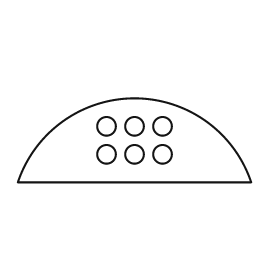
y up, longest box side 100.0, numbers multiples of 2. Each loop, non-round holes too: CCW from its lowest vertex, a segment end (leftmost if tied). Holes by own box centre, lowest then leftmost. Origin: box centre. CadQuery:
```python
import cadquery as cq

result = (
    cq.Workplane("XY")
    .moveTo(-50.0, -18.0)
    .lineTo(50.0, -18.0)
    .threePointArc((0.0, 18.0), (-50.0, -18.0))
    .close()
    .moveTo(-12.0, -6.0)
    .circle(4.0)
    .moveTo(0.0, -6.0)
    .circle(4.0)
    .moveTo(12.0, -6.0)
    .circle(4.0)
    .moveTo(-12.0, 6.0)
    .circle(4.0)
    .moveTo(0.0, 6.0)
    .circle(4.0)
    .moveTo(12.0, 6.0)
    .circle(4.0)
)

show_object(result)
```